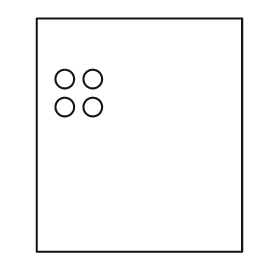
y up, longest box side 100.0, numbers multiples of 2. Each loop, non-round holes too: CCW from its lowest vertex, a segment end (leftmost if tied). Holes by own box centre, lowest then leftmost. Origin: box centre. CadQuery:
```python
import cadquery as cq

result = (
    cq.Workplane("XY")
    .moveTo(-44.0, -50.0)
    .lineTo(44.0, -50.0)
    .lineTo(44.0, 50.0)
    .lineTo(-44.0, 50.0)
    .close()
    .moveTo(-32.0, 12.0)
    .circle(4.0)
    .moveTo(-20.0, 12.0)
    .circle(4.0)
    .moveTo(-32.0, 24.0)
    .circle(4.0)
    .moveTo(-20.0, 24.0)
    .circle(4.0)
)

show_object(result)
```